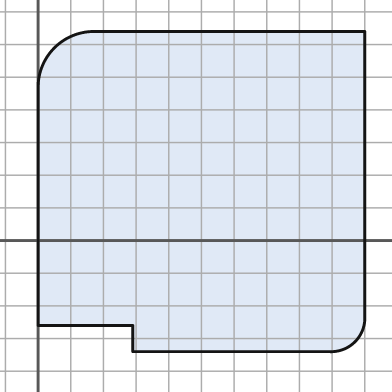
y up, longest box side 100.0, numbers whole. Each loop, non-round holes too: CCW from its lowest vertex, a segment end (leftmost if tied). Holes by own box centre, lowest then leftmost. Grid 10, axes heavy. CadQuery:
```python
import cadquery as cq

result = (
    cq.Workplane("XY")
    .moveTo(29.0, -34.0)
    .lineTo(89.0, -34.0)
    .threePointArc((97.0, -31.0), (100.0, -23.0))
    .lineTo(100.0, 64.0)
    .lineTo(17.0, 64.0)
    .threePointArc((5.0, 59.0), (0.0, 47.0))
    .lineTo(0.0, -26.0)
    .lineTo(29.0, -26.0)
    .close()
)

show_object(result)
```